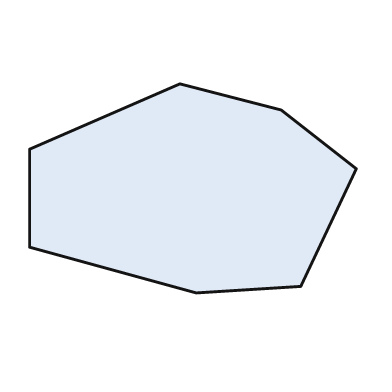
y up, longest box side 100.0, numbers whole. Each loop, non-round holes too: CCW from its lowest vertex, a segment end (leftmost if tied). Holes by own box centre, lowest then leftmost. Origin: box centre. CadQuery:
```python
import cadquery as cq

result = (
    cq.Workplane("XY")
    .moveTo(1.0, -32.0)
    .lineTo(33.0, -30.0)
    .lineTo(50.0, 6.0)
    .lineTo(27.0, 24.0)
    .lineTo(-4.0, 32.0)
    .lineTo(-50.0, 12.0)
    .lineTo(-50.0, -18.0)
    .close()
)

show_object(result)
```